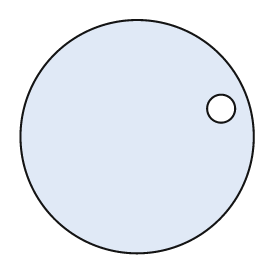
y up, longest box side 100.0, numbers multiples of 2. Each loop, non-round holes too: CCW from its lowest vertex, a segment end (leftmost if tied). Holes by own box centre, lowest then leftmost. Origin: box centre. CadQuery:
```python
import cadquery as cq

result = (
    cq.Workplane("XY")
    .moveTo(0.0, 0.0)
    .circle(50.0)
    .moveTo(36.0, 12.0)
    .circle(6.0)
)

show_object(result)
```